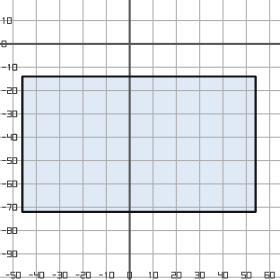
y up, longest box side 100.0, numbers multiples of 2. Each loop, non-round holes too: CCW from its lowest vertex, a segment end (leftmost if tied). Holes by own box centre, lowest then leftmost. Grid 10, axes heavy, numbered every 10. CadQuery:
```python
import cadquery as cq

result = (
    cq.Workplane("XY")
    .moveTo(-46.0, -72.0)
    .lineTo(54.0, -72.0)
    .lineTo(54.0, -14.0)
    .lineTo(-46.0, -14.0)
    .close()
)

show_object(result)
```